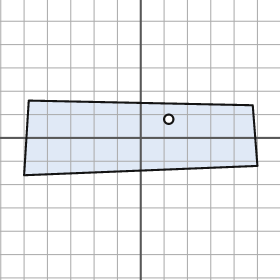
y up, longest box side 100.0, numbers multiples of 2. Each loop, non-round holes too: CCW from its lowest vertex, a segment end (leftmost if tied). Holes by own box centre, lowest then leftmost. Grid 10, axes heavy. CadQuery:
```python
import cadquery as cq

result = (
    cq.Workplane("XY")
    .moveTo(-50.0, -16.0)
    .lineTo(50.0, -12.0)
    .lineTo(48.0, 14.0)
    .lineTo(-48.0, 16.0)
    .close()
    .moveTo(12.0, 8.0)
    .circle(2.0)
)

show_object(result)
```